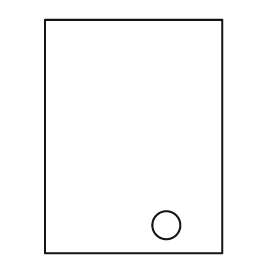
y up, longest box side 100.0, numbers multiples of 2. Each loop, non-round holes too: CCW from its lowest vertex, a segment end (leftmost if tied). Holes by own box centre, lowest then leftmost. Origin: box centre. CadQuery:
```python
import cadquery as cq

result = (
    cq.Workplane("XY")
    .moveTo(-38.0, -50.0)
    .lineTo(38.0, -50.0)
    .lineTo(38.0, 50.0)
    .lineTo(-38.0, 50.0)
    .close()
    .moveTo(14.0, -38.0)
    .circle(6.0)
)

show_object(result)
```